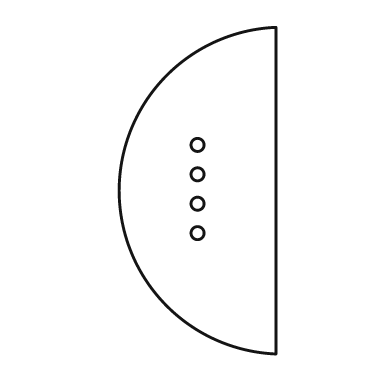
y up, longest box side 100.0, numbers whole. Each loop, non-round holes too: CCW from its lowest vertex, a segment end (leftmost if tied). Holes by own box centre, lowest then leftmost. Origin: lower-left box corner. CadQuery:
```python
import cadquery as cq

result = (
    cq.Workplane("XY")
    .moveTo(48.0, 0.0)
    .lineTo(48.0, 100.0)
    .threePointArc((0.0, 50.0), (48.0, 0.0))
    .close()
    .moveTo(24.0, 37.0)
    .circle(2.0)
    .moveTo(24.0, 46.0)
    .circle(2.0)
    .moveTo(24.0, 55.0)
    .circle(2.0)
    .moveTo(24.0, 64.0)
    .circle(2.0)
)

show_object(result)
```